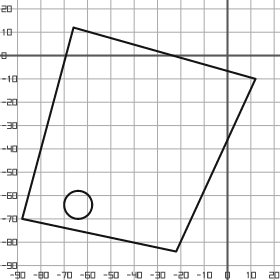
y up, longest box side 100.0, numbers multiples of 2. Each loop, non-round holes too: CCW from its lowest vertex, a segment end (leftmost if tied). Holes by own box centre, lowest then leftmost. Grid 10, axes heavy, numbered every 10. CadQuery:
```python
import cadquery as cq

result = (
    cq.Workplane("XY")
    .moveTo(-22.0, -84.0)
    .lineTo(12.0, -10.0)
    .lineTo(-66.0, 12.0)
    .lineTo(-88.0, -70.0)
    .close()
    .moveTo(-64.0, -64.0)
    .circle(6.0)
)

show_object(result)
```